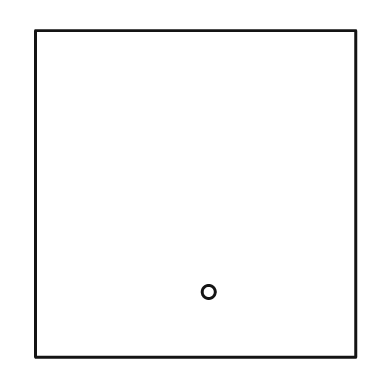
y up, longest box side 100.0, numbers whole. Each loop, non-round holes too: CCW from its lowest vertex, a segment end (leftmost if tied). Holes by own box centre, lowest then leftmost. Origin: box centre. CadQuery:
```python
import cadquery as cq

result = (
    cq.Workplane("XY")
    .moveTo(-49.0, -50.0)
    .lineTo(49.0, -50.0)
    .lineTo(49.0, 50.0)
    .lineTo(-49.0, 50.0)
    .close()
    .moveTo(4.0, -30.0)
    .circle(2.0)
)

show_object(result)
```